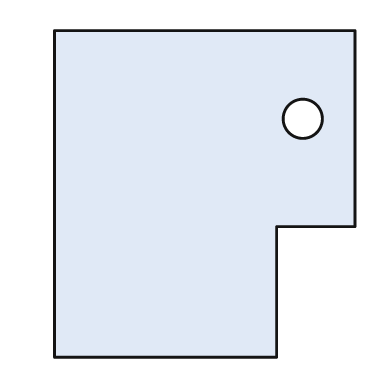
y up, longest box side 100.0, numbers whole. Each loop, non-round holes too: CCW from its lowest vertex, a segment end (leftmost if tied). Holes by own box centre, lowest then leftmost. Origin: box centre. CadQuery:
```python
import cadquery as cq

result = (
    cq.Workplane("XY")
    .moveTo(-46.0, -50.0)
    .lineTo(22.0, -50.0)
    .lineTo(22.0, -10.0)
    .lineTo(46.0, -10.0)
    .lineTo(46.0, 50.0)
    .lineTo(-46.0, 50.0)
    .close()
    .moveTo(30.0, 23.0)
    .circle(6.0)
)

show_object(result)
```